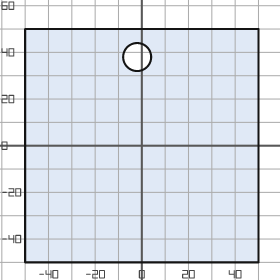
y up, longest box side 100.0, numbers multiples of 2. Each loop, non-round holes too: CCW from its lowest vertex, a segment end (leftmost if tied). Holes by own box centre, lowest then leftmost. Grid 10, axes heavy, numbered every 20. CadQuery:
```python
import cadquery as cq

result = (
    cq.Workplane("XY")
    .moveTo(-50.0, -50.0)
    .lineTo(50.0, -50.0)
    .lineTo(50.0, 50.0)
    .lineTo(-50.0, 50.0)
    .close()
    .moveTo(-2.0, 38.0)
    .circle(6.0)
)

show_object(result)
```